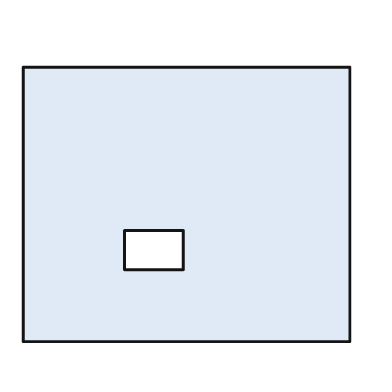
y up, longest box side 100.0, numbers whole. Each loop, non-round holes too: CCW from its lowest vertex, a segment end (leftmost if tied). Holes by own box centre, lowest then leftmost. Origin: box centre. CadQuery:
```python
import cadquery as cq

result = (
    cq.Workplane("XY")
    .moveTo(-50.0, -42.0)
    .lineTo(50.0, -42.0)
    .lineTo(50.0, 42.0)
    .lineTo(-50.0, 42.0)
    .close()
    .moveTo(-19.0, -20.0)
    .lineTo(-1.0, -20.0)
    .lineTo(-1.0, -8.0)
    .lineTo(-19.0, -8.0)
    .close()
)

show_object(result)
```